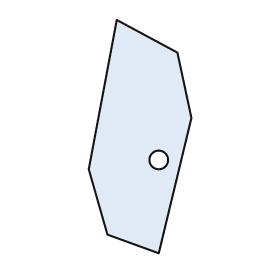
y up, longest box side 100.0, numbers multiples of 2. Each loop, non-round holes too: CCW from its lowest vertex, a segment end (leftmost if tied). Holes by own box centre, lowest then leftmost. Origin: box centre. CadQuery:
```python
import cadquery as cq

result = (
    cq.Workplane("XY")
    .moveTo(8.0, -50.0)
    .lineTo(22.0, 8.0)
    .lineTo(16.0, 36.0)
    .lineTo(-10.0, 50.0)
    .lineTo(-22.0, -14.0)
    .lineTo(-14.0, -42.0)
    .close()
    .moveTo(8.0, -10.0)
    .circle(4.0)
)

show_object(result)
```